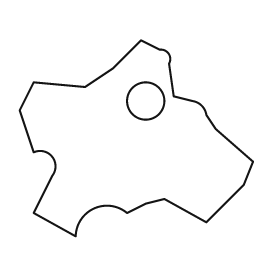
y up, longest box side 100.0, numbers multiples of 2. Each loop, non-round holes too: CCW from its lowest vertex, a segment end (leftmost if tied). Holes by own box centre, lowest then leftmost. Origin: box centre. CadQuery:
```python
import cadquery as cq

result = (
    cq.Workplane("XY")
    .moveTo(-26.0, -42.0)
    .threePointArc((-18.0, -30.0), (-4.0, -32.0))
    .lineTo(4.0, -28.0)
    .lineTo(12.0, -26.0)
    .lineTo(30.0, -36.0)
    .lineTo(46.0, -20.0)
    .lineTo(50.0, -10.0)
    .lineTo(34.0, 4.0)
    .lineTo(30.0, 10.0)
    .threePointArc((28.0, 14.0), (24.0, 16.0))
    .lineTo(16.0, 18.0)
    .lineTo(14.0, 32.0)
    .threePointArc((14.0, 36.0), (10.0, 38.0))
    .lineTo(2.0, 42.0)
    .lineTo(-10.0, 30.0)
    .lineTo(-22.0, 22.0)
    .lineTo(-44.0, 24.0)
    .lineTo(-50.0, 12.0)
    .lineTo(-44.0, -6.0)
    .threePointArc((-36.0, -8.0), (-36.0, -16.0))
    .lineTo(-44.0, -32.0)
    .close()
    .moveTo(4.0, 16.0)
    .circle(8.0)
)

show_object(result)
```